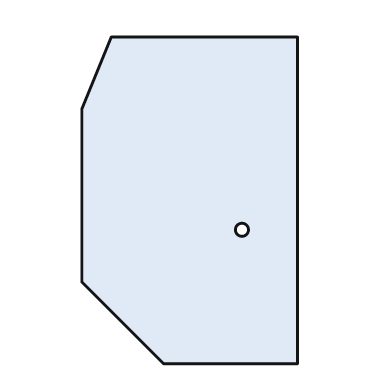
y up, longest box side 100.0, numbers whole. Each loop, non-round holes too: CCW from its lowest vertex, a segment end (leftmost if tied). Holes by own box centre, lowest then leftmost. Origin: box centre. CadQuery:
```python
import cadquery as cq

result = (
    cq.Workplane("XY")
    .moveTo(-8.0, -50.0)
    .lineTo(33.0, -50.0)
    .lineTo(33.0, 50.0)
    .lineTo(-24.0, 50.0)
    .lineTo(-33.0, 28.0)
    .lineTo(-33.0, -25.0)
    .close()
    .moveTo(16.0, -9.0)
    .circle(2.0)
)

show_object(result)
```